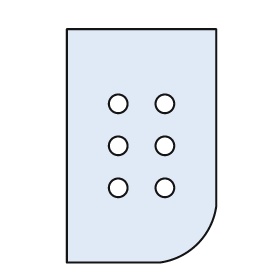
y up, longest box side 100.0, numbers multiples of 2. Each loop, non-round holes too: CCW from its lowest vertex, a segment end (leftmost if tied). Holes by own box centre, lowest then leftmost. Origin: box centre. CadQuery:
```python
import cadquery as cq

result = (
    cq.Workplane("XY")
    .moveTo(-32.0, -50.0)
    .lineTo(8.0, -50.0)
    .threePointArc((24.0, -42.0), (32.0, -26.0))
    .lineTo(32.0, 50.0)
    .lineTo(-32.0, 50.0)
    .close()
    .moveTo(-10.0, -18.0)
    .circle(4.0)
    .moveTo(10.0, -18.0)
    .circle(4.0)
    .moveTo(-10.0, 0.0)
    .circle(4.0)
    .moveTo(10.0, 0.0)
    .circle(4.0)
    .moveTo(-10.0, 18.0)
    .circle(4.0)
    .moveTo(10.0, 18.0)
    .circle(4.0)
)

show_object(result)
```